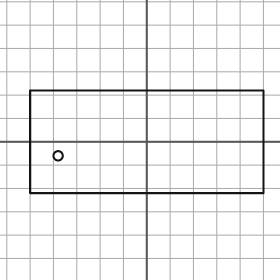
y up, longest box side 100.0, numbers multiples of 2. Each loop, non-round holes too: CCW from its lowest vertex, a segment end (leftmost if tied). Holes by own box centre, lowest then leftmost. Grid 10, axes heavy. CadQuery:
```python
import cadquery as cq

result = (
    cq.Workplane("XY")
    .moveTo(-50.0, -22.0)
    .lineTo(50.0, -22.0)
    .lineTo(50.0, 22.0)
    .lineTo(-50.0, 22.0)
    .close()
    .moveTo(-38.0, -6.0)
    .circle(2.0)
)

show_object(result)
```